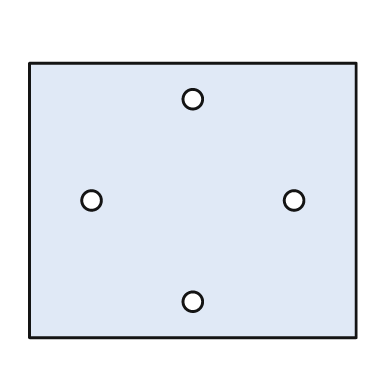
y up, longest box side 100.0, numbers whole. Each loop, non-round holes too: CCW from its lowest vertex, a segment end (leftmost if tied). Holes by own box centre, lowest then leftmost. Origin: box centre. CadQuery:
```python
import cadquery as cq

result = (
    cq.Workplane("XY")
    .moveTo(-50.0, -42.0)
    .lineTo(50.0, -42.0)
    .lineTo(50.0, 42.0)
    .lineTo(-50.0, 42.0)
    .close()
    .moveTo(0.0, -31.0)
    .circle(3.0)
    .moveTo(-31.0, 0.0)
    .circle(3.0)
    .moveTo(31.0, 0.0)
    .circle(3.0)
    .moveTo(0.0, 31.0)
    .circle(3.0)
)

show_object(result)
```